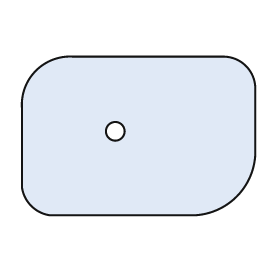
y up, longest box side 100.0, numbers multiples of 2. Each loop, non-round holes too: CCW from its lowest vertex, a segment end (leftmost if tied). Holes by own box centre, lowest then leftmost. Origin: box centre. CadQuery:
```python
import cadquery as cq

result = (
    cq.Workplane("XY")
    .moveTo(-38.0, -34.0)
    .lineTo(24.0, -34.0)
    .threePointArc((42.0, -26.0), (50.0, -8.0))
    .lineTo(50.0, 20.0)
    .threePointArc((46.0, 30.0), (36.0, 34.0))
    .lineTo(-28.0, 34.0)
    .threePointArc((-44.0, 28.0), (-50.0, 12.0))
    .lineTo(-50.0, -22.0)
    .threePointArc((-46.0, -30.0), (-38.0, -34.0))
    .close()
    .moveTo(-10.0, 2.0)
    .circle(4.0)
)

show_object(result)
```